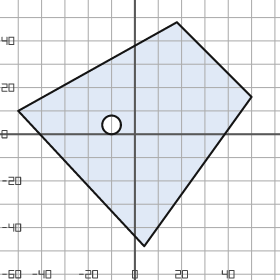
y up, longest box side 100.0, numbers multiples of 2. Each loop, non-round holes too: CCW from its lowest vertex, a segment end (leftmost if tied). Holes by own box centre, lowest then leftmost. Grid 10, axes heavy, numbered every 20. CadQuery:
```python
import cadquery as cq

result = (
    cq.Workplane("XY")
    .moveTo(4.0, -48.0)
    .lineTo(50.0, 16.0)
    .lineTo(18.0, 48.0)
    .lineTo(-50.0, 10.0)
    .close()
    .moveTo(-10.0, 4.0)
    .circle(4.0)
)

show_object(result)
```